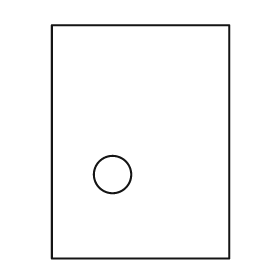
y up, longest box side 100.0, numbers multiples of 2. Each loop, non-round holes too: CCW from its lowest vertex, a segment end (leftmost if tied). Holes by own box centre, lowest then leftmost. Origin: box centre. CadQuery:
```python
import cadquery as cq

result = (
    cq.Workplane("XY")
    .moveTo(-38.0, -50.0)
    .lineTo(38.0, -50.0)
    .lineTo(38.0, 50.0)
    .lineTo(-38.0, 50.0)
    .close()
    .moveTo(-12.0, -14.0)
    .circle(8.0)
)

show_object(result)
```